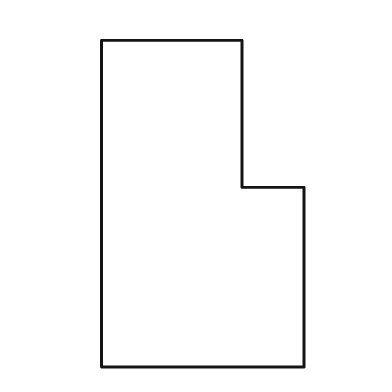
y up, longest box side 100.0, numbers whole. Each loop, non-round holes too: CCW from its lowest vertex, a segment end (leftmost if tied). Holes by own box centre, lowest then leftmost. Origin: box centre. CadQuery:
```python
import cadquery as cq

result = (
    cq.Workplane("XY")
    .moveTo(-31.0, -50.0)
    .lineTo(31.0, -50.0)
    .lineTo(31.0, 5.0)
    .lineTo(12.0, 5.0)
    .lineTo(12.0, 50.0)
    .lineTo(-31.0, 50.0)
    .close()
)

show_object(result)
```